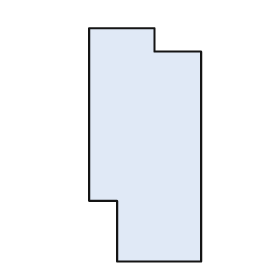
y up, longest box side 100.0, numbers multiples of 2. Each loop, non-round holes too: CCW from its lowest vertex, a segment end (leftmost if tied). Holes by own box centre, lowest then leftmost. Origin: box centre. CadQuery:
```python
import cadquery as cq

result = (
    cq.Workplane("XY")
    .moveTo(-12.0, -50.0)
    .lineTo(24.0, -50.0)
    .lineTo(24.0, 40.0)
    .lineTo(4.0, 40.0)
    .lineTo(4.0, 50.0)
    .lineTo(-24.0, 50.0)
    .lineTo(-24.0, -24.0)
    .lineTo(-12.0, -24.0)
    .close()
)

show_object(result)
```